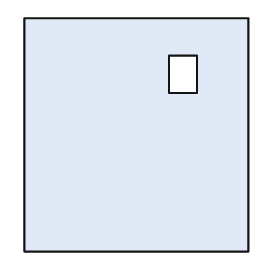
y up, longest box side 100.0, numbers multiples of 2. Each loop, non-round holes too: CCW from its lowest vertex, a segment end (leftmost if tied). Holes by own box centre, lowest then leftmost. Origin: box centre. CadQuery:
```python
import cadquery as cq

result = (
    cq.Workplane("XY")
    .moveTo(-48.0, -50.0)
    .lineTo(48.0, -50.0)
    .lineTo(48.0, 50.0)
    .lineTo(-48.0, 50.0)
    .close()
    .moveTo(14.0, 18.0)
    .lineTo(26.0, 18.0)
    .lineTo(26.0, 34.0)
    .lineTo(14.0, 34.0)
    .close()
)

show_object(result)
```